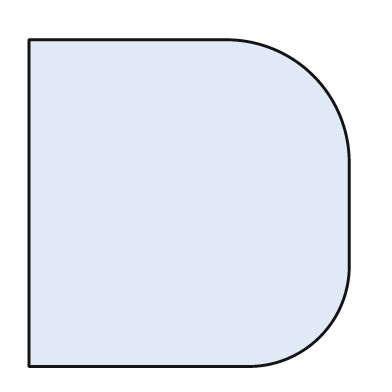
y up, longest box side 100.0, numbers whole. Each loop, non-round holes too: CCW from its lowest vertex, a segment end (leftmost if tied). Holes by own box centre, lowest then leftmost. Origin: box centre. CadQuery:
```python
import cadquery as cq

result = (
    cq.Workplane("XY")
    .moveTo(-49.0, -50.0)
    .lineTo(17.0, -50.0)
    .threePointArc((40.0, -41.0), (49.0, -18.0))
    .lineTo(49.0, 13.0)
    .threePointArc((38.0, 39.0), (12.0, 50.0))
    .lineTo(-49.0, 50.0)
    .close()
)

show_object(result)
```